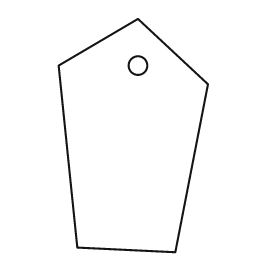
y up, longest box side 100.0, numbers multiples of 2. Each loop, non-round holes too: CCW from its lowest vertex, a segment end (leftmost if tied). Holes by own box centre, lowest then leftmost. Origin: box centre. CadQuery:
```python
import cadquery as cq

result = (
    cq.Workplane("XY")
    .moveTo(18.0, -50.0)
    .lineTo(32.0, 22.0)
    .lineTo(2.0, 50.0)
    .lineTo(-32.0, 30.0)
    .lineTo(-24.0, -48.0)
    .close()
    .moveTo(2.0, 30.0)
    .circle(4.0)
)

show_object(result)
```